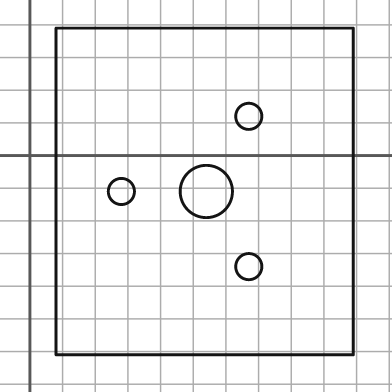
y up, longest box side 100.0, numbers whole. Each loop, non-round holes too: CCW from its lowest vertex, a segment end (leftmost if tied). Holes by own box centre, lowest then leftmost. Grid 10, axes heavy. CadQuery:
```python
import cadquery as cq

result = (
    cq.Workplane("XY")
    .moveTo(8.0, -61.0)
    .lineTo(99.0, -61.0)
    .lineTo(99.0, 39.0)
    .lineTo(8.0, 39.0)
    .close()
    .moveTo(67.0, -34.0)
    .circle(4.0)
    .moveTo(28.0, -11.0)
    .circle(4.0)
    .moveTo(54.0, -11.0)
    .circle(8.0)
    .moveTo(67.0, 12.0)
    .circle(4.0)
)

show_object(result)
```